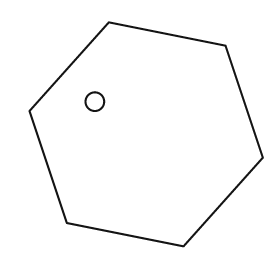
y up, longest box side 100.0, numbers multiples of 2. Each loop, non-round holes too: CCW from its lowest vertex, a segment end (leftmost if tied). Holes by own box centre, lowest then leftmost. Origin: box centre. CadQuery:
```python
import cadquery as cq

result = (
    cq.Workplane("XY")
    .moveTo(16.0, -48.0)
    .lineTo(50.0, -10.0)
    .lineTo(34.0, 38.0)
    .lineTo(-16.0, 48.0)
    .lineTo(-50.0, 10.0)
    .lineTo(-34.0, -38.0)
    .close()
    .moveTo(-22.0, 14.0)
    .circle(4.0)
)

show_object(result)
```